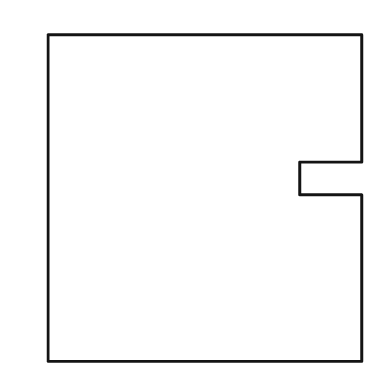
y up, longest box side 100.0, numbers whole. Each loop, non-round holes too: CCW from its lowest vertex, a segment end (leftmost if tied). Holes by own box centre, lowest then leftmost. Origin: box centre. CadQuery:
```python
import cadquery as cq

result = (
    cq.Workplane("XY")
    .moveTo(-48.0, -50.0)
    .lineTo(48.0, -50.0)
    .lineTo(48.0, 1.0)
    .lineTo(29.0, 1.0)
    .lineTo(29.0, 11.0)
    .lineTo(48.0, 11.0)
    .lineTo(48.0, 50.0)
    .lineTo(-48.0, 50.0)
    .close()
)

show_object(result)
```